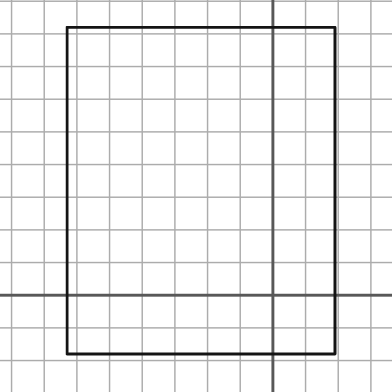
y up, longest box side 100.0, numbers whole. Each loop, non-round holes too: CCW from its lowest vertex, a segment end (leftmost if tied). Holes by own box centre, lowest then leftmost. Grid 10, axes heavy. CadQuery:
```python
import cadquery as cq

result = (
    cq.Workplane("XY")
    .moveTo(-63.0, -18.0)
    .lineTo(19.0, -18.0)
    .lineTo(19.0, 82.0)
    .lineTo(-63.0, 82.0)
    .close()
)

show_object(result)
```